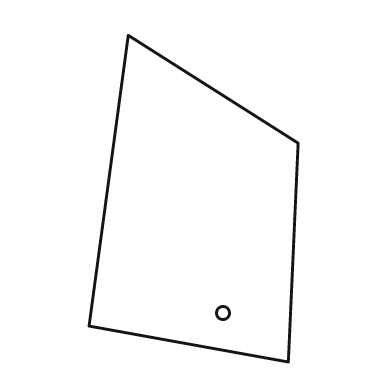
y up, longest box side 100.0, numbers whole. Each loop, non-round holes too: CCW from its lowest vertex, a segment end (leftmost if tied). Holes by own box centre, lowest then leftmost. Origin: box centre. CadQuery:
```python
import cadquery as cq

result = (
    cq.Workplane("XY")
    .moveTo(29.0, -50.0)
    .lineTo(32.0, 17.0)
    .lineTo(-20.0, 50.0)
    .lineTo(-32.0, -39.0)
    .close()
    .moveTo(9.0, -35.0)
    .circle(2.0)
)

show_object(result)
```